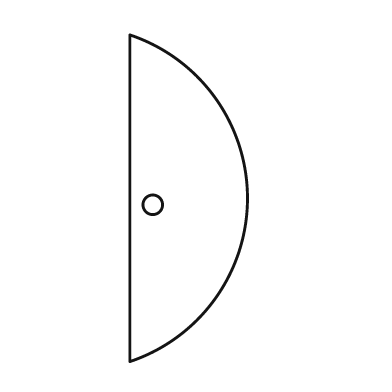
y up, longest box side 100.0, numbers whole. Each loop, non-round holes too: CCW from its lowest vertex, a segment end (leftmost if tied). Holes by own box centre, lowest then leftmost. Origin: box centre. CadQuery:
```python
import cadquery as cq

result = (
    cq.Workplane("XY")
    .moveTo(-18.0, -50.0)
    .threePointArc((18.0, 0.0), (-18.0, 50.0))
    .close()
    .moveTo(-11.0, -2.0)
    .circle(3.0)
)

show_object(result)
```